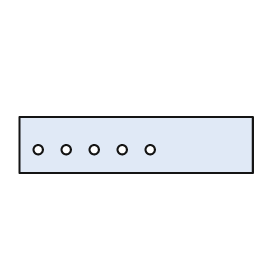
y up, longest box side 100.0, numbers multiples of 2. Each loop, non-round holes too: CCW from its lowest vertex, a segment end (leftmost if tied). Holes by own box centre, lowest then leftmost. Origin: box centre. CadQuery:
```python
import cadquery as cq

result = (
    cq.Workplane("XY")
    .moveTo(-50.0, -12.0)
    .lineTo(50.0, -12.0)
    .lineTo(50.0, 12.0)
    .lineTo(-50.0, 12.0)
    .close()
    .moveTo(-42.0, -2.0)
    .circle(2.0)
    .moveTo(-30.0, -2.0)
    .circle(2.0)
    .moveTo(-18.0, -2.0)
    .circle(2.0)
    .moveTo(-6.0, -2.0)
    .circle(2.0)
    .moveTo(6.0, -2.0)
    .circle(2.0)
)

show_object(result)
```